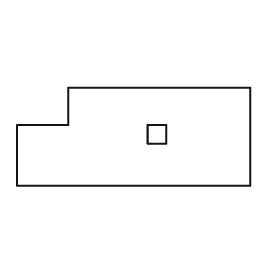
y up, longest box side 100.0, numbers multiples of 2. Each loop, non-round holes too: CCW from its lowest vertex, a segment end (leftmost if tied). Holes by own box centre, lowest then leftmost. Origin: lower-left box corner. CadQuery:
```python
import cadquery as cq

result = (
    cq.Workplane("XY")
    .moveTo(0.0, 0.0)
    .lineTo(100.0, 0.0)
    .lineTo(100.0, 42.0)
    .lineTo(22.0, 42.0)
    .lineTo(22.0, 26.0)
    .lineTo(0.0, 26.0)
    .close()
    .moveTo(56.0, 18.0)
    .lineTo(64.0, 18.0)
    .lineTo(64.0, 26.0)
    .lineTo(56.0, 26.0)
    .close()
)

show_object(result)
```